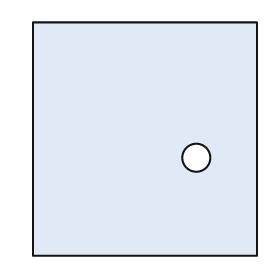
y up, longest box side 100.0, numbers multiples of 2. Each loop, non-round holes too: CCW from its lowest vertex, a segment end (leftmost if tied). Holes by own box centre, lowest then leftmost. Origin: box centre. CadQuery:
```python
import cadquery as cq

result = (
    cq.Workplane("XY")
    .moveTo(-48.0, -50.0)
    .lineTo(48.0, -50.0)
    .lineTo(48.0, 50.0)
    .lineTo(-48.0, 50.0)
    .close()
    .moveTo(22.0, -8.0)
    .circle(6.0)
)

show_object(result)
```